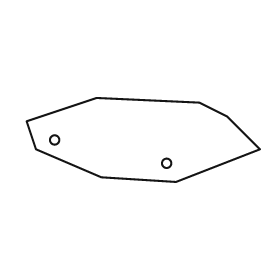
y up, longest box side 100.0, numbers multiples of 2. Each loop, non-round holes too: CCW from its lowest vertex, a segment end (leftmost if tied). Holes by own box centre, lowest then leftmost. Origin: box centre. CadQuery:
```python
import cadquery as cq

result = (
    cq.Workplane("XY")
    .moveTo(14.0, -18.0)
    .lineTo(50.0, -4.0)
    .lineTo(36.0, 10.0)
    .lineTo(24.0, 16.0)
    .lineTo(-20.0, 18.0)
    .lineTo(-50.0, 8.0)
    .lineTo(-46.0, -4.0)
    .lineTo(-18.0, -16.0)
    .close()
    .moveTo(10.0, -10.0)
    .circle(2.0)
    .moveTo(-38.0, 0.0)
    .circle(2.0)
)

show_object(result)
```